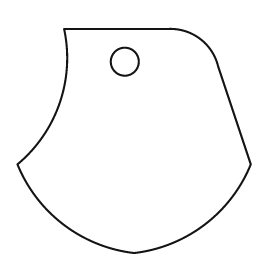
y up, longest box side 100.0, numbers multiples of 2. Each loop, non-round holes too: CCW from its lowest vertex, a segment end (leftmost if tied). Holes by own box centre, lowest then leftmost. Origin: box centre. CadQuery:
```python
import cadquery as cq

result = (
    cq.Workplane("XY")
    .moveTo(0.0, -48.0)
    .threePointArc((30.0, -36.0), (50.0, -10.0))
    .lineTo(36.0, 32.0)
    .threePointArc((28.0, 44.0), (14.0, 48.0))
    .lineTo(-30.0, 48.0)
    .threePointArc((-32.0, 16.0), (-50.0, -10.0))
    .threePointArc((-30.0, -36.0), (0.0, -48.0))
    .close()
    .moveTo(-4.0, 34.0)
    .circle(6.0)
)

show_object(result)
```